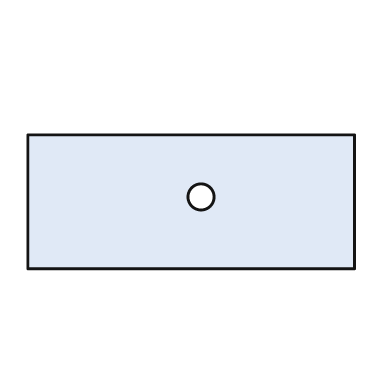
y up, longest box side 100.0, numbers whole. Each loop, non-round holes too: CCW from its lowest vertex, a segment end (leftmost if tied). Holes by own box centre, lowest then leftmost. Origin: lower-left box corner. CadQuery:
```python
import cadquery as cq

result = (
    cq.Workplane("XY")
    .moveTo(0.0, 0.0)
    .lineTo(100.0, 0.0)
    .lineTo(100.0, 41.0)
    .lineTo(0.0, 41.0)
    .close()
    .moveTo(53.0, 22.0)
    .circle(4.0)
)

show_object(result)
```